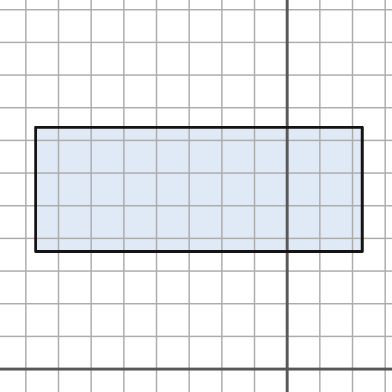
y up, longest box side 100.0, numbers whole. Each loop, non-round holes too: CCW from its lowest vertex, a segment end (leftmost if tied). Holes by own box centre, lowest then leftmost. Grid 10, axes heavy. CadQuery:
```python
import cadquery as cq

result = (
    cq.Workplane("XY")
    .moveTo(-77.0, 36.0)
    .lineTo(23.0, 36.0)
    .lineTo(23.0, 74.0)
    .lineTo(-77.0, 74.0)
    .close()
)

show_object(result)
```